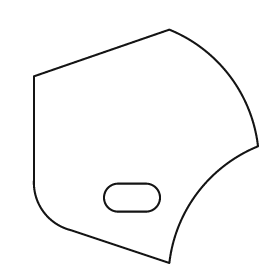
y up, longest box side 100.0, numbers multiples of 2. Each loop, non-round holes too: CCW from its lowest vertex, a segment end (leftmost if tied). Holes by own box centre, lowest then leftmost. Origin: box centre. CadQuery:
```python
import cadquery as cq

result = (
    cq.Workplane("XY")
    .moveTo(10.0, -50.0)
    .threePointArc((22.0, -20.0), (48.0, 0.0))
    .threePointArc((36.0, 30.0), (10.0, 50.0))
    .lineTo(-48.0, 30.0)
    .lineTo(-48.0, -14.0)
    .threePointArc((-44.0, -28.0), (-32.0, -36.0))
    .close()
    .moveTo(-12.0, -28.0)
    .lineTo(0.0, -28.0)
    .threePointArc((6.0, -22.0), (0.0, -16.0))
    .lineTo(-12.0, -16.0)
    .threePointArc((-18.0, -22.0), (-12.0, -28.0))
    .close()
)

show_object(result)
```